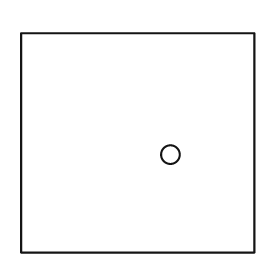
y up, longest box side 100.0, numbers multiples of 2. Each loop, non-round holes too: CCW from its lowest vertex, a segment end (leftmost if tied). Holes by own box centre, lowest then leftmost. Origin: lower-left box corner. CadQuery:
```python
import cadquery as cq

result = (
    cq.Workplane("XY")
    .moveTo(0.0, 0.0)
    .lineTo(100.0, 0.0)
    .lineTo(100.0, 94.0)
    .lineTo(0.0, 94.0)
    .close()
    .moveTo(64.0, 42.0)
    .circle(4.0)
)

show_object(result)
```